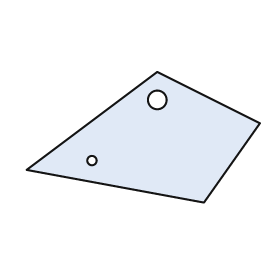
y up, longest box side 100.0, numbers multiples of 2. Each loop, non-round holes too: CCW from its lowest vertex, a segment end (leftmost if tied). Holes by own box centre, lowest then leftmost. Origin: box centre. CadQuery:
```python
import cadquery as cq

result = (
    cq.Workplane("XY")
    .moveTo(26.0, -28.0)
    .lineTo(50.0, 6.0)
    .lineTo(6.0, 28.0)
    .lineTo(-50.0, -14.0)
    .close()
    .moveTo(-22.0, -10.0)
    .circle(2.0)
    .moveTo(6.0, 16.0)
    .circle(4.0)
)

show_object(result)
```